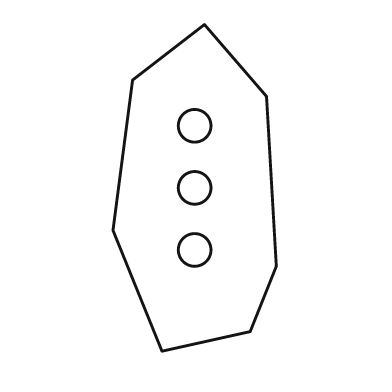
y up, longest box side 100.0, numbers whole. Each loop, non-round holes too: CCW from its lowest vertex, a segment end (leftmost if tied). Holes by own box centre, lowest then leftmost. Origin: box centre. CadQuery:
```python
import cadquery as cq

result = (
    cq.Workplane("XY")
    .moveTo(-10.0, -50.0)
    .lineTo(17.0, -44.0)
    .lineTo(25.0, -24.0)
    .lineTo(22.0, 28.0)
    .lineTo(3.0, 50.0)
    .lineTo(-19.0, 33.0)
    .lineTo(-25.0, -13.0)
    .close()
    .moveTo(0.0, -19.0)
    .circle(5.0)
    .moveTo(0.0, 0.0)
    .circle(5.0)
    .moveTo(0.0, 19.0)
    .circle(5.0)
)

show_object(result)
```